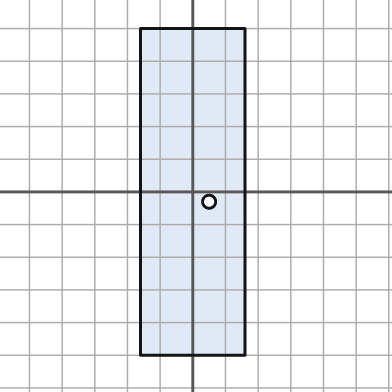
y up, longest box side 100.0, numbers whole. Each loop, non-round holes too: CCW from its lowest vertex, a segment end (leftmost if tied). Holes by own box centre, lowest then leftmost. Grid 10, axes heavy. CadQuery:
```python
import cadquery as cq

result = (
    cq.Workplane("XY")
    .moveTo(-16.0, -50.0)
    .lineTo(16.0, -50.0)
    .lineTo(16.0, 50.0)
    .lineTo(-16.0, 50.0)
    .close()
    .moveTo(5.0, -3.0)
    .circle(2.0)
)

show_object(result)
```